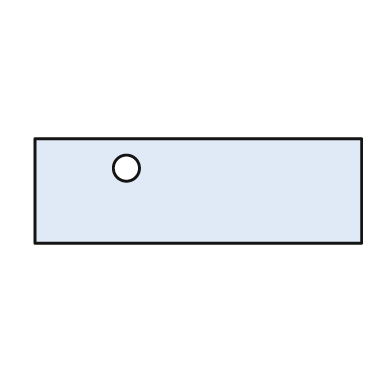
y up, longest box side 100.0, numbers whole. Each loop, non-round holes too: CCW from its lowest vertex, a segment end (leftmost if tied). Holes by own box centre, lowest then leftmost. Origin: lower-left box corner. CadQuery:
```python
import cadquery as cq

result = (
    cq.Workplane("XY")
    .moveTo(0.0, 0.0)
    .lineTo(100.0, 0.0)
    .lineTo(100.0, 32.0)
    .lineTo(0.0, 32.0)
    .close()
    .moveTo(28.0, 23.0)
    .circle(4.0)
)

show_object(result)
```